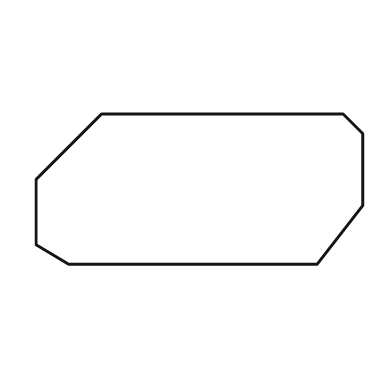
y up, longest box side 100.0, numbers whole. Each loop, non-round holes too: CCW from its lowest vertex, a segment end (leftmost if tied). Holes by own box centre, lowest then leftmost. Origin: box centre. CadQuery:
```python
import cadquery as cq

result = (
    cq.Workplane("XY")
    .moveTo(-40.0, -23.0)
    .lineTo(36.0, -23.0)
    .lineTo(50.0, -5.0)
    .lineTo(50.0, 17.0)
    .lineTo(44.0, 23.0)
    .lineTo(-30.0, 23.0)
    .lineTo(-50.0, 3.0)
    .lineTo(-50.0, -17.0)
    .close()
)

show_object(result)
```